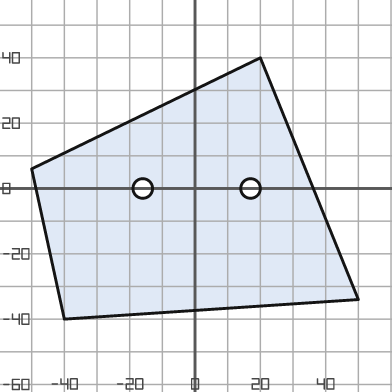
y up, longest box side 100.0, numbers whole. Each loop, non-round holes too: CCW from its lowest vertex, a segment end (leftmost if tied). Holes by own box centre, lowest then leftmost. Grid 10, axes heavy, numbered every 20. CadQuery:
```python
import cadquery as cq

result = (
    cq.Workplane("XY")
    .moveTo(-40.0, -40.0)
    .lineTo(50.0, -34.0)
    .lineTo(20.0, 40.0)
    .lineTo(-50.0, 6.0)
    .close()
    .moveTo(-16.0, 0.0)
    .circle(3.0)
    .moveTo(17.0, 0.0)
    .circle(3.0)
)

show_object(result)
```